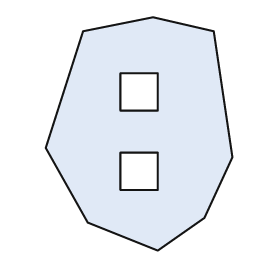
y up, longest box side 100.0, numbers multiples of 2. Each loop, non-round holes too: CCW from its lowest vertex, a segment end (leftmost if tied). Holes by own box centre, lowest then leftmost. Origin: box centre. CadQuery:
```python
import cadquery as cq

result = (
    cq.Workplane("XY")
    .moveTo(8.0, -50.0)
    .lineTo(28.0, -36.0)
    .lineTo(40.0, -10.0)
    .lineTo(32.0, 44.0)
    .lineTo(6.0, 50.0)
    .lineTo(-24.0, 44.0)
    .lineTo(-40.0, -6.0)
    .lineTo(-22.0, -38.0)
    .close()
    .moveTo(-8.0, -24.0)
    .lineTo(8.0, -24.0)
    .lineTo(8.0, -8.0)
    .lineTo(-8.0, -8.0)
    .close()
    .moveTo(-8.0, 10.0)
    .lineTo(8.0, 10.0)
    .lineTo(8.0, 26.0)
    .lineTo(-8.0, 26.0)
    .close()
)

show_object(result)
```